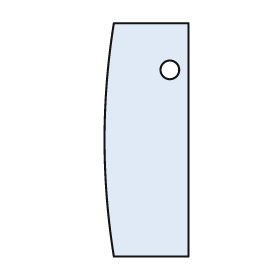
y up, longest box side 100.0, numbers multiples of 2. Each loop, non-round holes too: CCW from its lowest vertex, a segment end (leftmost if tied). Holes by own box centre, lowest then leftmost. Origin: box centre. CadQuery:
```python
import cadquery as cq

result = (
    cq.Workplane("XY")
    .moveTo(-14.0, -50.0)
    .lineTo(18.0, -50.0)
    .lineTo(18.0, 50.0)
    .lineTo(-14.0, 50.0)
    .threePointArc((-18.0, 0.0), (-14.0, -50.0))
    .close()
    .moveTo(10.0, 30.0)
    .circle(4.0)
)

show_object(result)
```